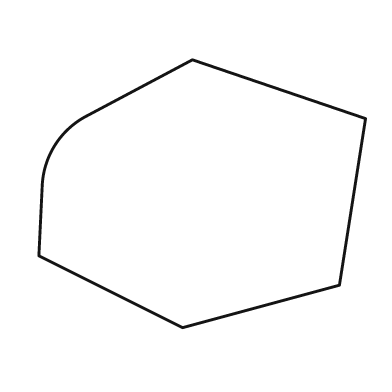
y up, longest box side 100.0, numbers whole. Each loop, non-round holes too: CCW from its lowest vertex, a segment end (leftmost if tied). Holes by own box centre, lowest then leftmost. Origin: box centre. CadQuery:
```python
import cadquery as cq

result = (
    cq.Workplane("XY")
    .moveTo(-6.0, -41.0)
    .lineTo(42.0, -28.0)
    .lineTo(50.0, 23.0)
    .lineTo(-3.0, 41.0)
    .lineTo(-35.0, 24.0)
    .threePointArc((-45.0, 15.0), (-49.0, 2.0))
    .lineTo(-50.0, -19.0)
    .close()
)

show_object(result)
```